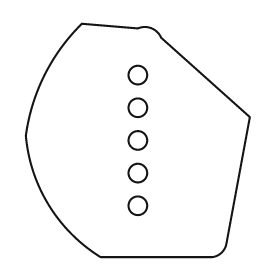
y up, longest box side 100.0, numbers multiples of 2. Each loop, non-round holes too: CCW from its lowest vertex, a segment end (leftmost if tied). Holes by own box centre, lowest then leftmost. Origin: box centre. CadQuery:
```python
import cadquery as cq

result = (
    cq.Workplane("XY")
    .moveTo(-16.0, -50.0)
    .lineTo(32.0, -50.0)
    .threePointArc((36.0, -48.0), (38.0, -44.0))
    .lineTo(48.0, 10.0)
    .lineTo(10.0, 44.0)
    .threePointArc((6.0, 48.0), (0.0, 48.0))
    .lineTo(-24.0, 50.0)
    .threePointArc((-40.0, 28.0), (-48.0, 2.0))
    .threePointArc((-38.0, -28.0), (-16.0, -50.0))
    .close()
    .moveTo(0.0, -28.0)
    .circle(4.0)
    .moveTo(0.0, -14.0)
    .circle(4.0)
    .moveTo(0.0, 0.0)
    .circle(4.0)
    .moveTo(0.0, 14.0)
    .circle(4.0)
    .moveTo(0.0, 28.0)
    .circle(4.0)
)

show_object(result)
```